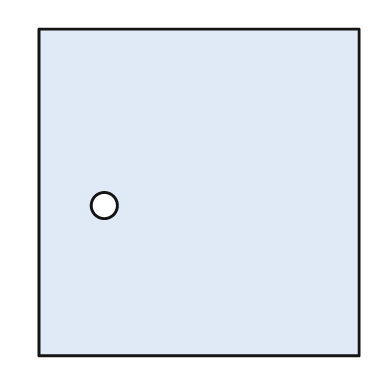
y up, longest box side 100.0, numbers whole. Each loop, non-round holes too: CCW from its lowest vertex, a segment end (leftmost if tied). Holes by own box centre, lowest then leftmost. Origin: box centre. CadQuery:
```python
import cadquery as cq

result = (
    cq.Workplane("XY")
    .moveTo(-49.0, -50.0)
    .lineTo(49.0, -50.0)
    .lineTo(49.0, 50.0)
    .lineTo(-49.0, 50.0)
    .close()
    .moveTo(-29.0, -4.0)
    .circle(4.0)
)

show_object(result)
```